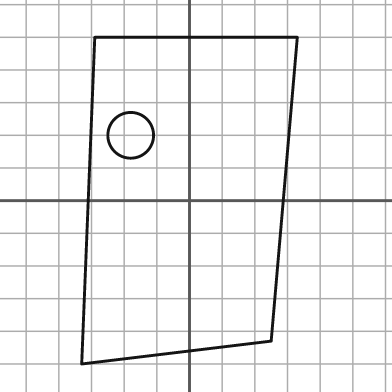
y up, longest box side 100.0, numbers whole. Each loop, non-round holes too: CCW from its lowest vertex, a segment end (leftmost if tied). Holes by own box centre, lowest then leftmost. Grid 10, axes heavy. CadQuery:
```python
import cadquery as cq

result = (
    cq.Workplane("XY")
    .moveTo(-33.0, -50.0)
    .lineTo(25.0, -43.0)
    .lineTo(33.0, 50.0)
    .lineTo(-29.0, 50.0)
    .close()
    .moveTo(-18.0, 20.0)
    .circle(7.0)
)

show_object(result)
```